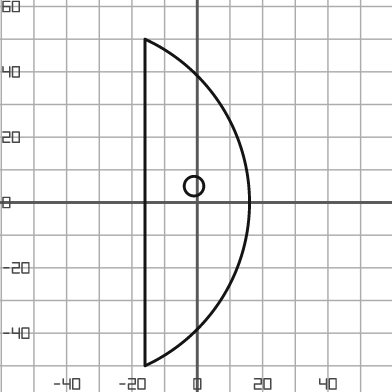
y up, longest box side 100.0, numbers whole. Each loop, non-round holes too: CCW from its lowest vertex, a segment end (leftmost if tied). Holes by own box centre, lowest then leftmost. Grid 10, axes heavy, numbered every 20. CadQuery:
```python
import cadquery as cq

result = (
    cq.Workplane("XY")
    .moveTo(-16.0, -50.0)
    .threePointArc((16.0, 0.0), (-16.0, 50.0))
    .close()
    .moveTo(-1.0, 5.0)
    .circle(3.0)
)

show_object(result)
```